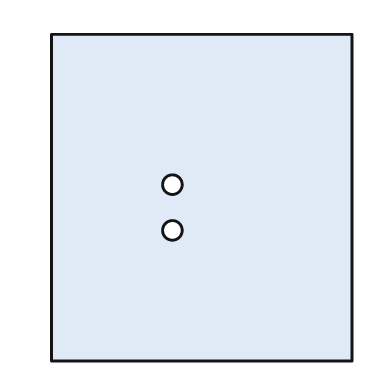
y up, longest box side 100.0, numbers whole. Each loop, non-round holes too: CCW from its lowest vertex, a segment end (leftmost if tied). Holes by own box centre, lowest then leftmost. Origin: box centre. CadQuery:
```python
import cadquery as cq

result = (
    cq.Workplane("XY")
    .moveTo(-46.0, -50.0)
    .lineTo(46.0, -50.0)
    .lineTo(46.0, 50.0)
    .lineTo(-46.0, 50.0)
    .close()
    .moveTo(-9.0, -10.0)
    .circle(3.0)
    .moveTo(-9.0, 4.0)
    .circle(3.0)
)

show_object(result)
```